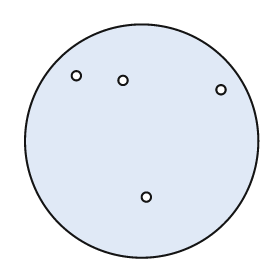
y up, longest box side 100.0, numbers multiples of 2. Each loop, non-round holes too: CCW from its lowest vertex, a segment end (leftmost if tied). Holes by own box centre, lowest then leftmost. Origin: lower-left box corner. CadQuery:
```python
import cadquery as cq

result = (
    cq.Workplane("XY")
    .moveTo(50.0, 50.0)
    .circle(50.0)
    .moveTo(52.0, 26.0)
    .circle(2.0)
    .moveTo(84.0, 72.0)
    .circle(2.0)
    .moveTo(42.0, 76.0)
    .circle(2.0)
    .moveTo(22.0, 78.0)
    .circle(2.0)
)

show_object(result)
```